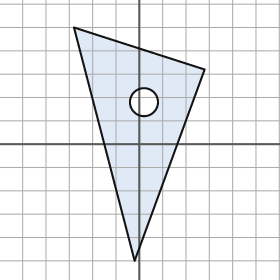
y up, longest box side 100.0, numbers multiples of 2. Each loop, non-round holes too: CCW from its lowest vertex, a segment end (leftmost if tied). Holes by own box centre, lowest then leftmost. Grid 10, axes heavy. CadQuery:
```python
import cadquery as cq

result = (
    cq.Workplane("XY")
    .moveTo(-2.0, -50.0)
    .lineTo(28.0, 32.0)
    .lineTo(-28.0, 50.0)
    .close()
    .moveTo(2.0, 18.0)
    .circle(6.0)
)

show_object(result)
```